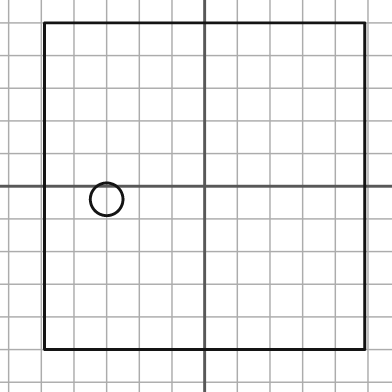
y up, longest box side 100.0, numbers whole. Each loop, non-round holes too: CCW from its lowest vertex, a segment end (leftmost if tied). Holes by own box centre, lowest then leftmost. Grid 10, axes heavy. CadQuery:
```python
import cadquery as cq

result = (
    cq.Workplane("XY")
    .moveTo(-49.0, -50.0)
    .lineTo(49.0, -50.0)
    .lineTo(49.0, 50.0)
    .lineTo(-49.0, 50.0)
    .close()
    .moveTo(-30.0, -4.0)
    .circle(5.0)
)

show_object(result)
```